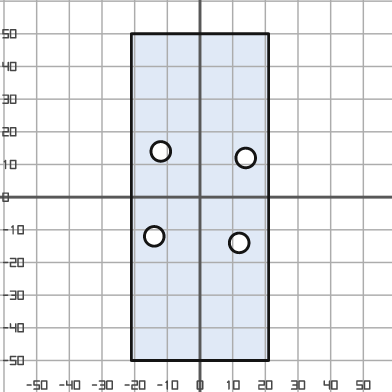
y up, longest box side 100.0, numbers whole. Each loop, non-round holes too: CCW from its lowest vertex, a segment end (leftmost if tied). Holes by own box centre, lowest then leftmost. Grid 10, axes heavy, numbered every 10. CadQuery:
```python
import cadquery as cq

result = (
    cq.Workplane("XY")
    .moveTo(-21.0, -50.0)
    .lineTo(21.0, -50.0)
    .lineTo(21.0, 50.0)
    .lineTo(-21.0, 50.0)
    .close()
    .moveTo(12.0, -14.0)
    .circle(3.0)
    .moveTo(-14.0, -12.0)
    .circle(3.0)
    .moveTo(14.0, 12.0)
    .circle(3.0)
    .moveTo(-12.0, 14.0)
    .circle(3.0)
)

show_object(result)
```